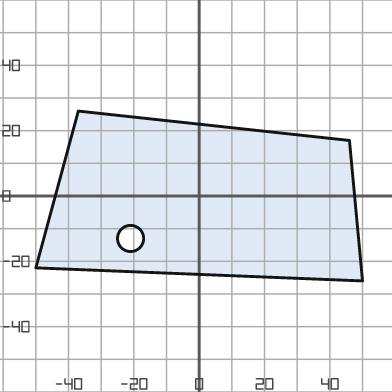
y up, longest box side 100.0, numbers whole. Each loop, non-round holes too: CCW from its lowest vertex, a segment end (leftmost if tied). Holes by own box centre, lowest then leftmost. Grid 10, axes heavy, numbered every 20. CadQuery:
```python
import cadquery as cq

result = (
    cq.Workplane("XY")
    .moveTo(50.0, -26.0)
    .lineTo(46.0, 17.0)
    .lineTo(-37.0, 26.0)
    .lineTo(-50.0, -22.0)
    .close()
    .moveTo(-21.0, -13.0)
    .circle(4.0)
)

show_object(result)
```